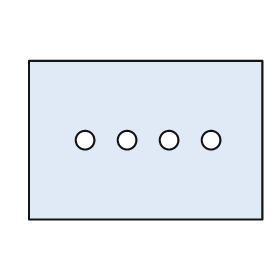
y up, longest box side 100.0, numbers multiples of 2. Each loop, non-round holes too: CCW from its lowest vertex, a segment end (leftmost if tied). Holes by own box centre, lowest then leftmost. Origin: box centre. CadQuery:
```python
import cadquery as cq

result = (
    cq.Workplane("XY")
    .moveTo(-50.0, -34.0)
    .lineTo(50.0, -34.0)
    .lineTo(50.0, 34.0)
    .lineTo(-50.0, 34.0)
    .close()
    .moveTo(-26.0, 0.0)
    .circle(4.0)
    .moveTo(-8.0, 0.0)
    .circle(4.0)
    .moveTo(10.0, 0.0)
    .circle(4.0)
    .moveTo(28.0, 0.0)
    .circle(4.0)
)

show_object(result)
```